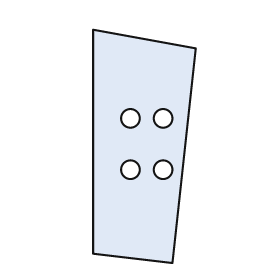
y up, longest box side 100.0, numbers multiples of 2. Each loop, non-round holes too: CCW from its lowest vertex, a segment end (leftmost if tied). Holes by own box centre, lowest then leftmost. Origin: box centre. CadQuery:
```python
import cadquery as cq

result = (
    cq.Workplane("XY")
    .moveTo(12.0, -50.0)
    .lineTo(22.0, 42.0)
    .lineTo(-22.0, 50.0)
    .lineTo(-22.0, -46.0)
    .close()
    .moveTo(-6.0, -10.0)
    .circle(4.0)
    .moveTo(8.0, -10.0)
    .circle(4.0)
    .moveTo(-6.0, 12.0)
    .circle(4.0)
    .moveTo(8.0, 12.0)
    .circle(4.0)
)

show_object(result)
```